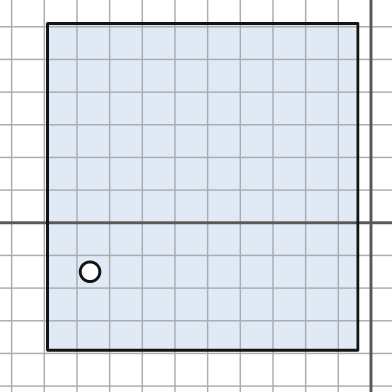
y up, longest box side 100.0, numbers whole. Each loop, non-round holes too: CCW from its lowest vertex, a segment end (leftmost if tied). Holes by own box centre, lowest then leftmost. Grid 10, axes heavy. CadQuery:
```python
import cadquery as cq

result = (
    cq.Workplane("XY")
    .moveTo(-99.0, -39.0)
    .lineTo(-4.0, -39.0)
    .lineTo(-4.0, 61.0)
    .lineTo(-99.0, 61.0)
    .close()
    .moveTo(-86.0, -15.0)
    .circle(3.0)
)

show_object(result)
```